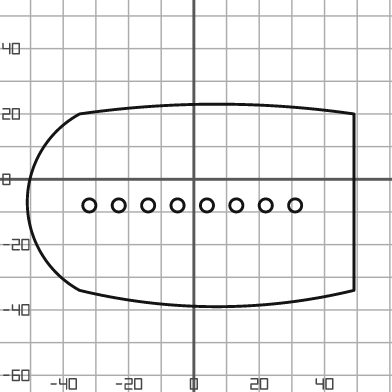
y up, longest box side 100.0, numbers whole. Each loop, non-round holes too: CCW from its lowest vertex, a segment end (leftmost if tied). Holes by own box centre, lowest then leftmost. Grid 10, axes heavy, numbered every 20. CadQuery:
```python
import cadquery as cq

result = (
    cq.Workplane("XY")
    .moveTo(-35.0, -34.0)
    .threePointArc((7.0, -39.0), (49.0, -34.0))
    .lineTo(49.0, 20.0)
    .threePointArc((7.0, 23.0), (-35.0, 20.0))
    .threePointArc((-51.0, -7.0), (-35.0, -34.0))
    .close()
    .moveTo(-32.0, -8.0)
    .circle(2.0)
    .moveTo(-23.0, -8.0)
    .circle(2.0)
    .moveTo(-14.0, -8.0)
    .circle(2.0)
    .moveTo(-5.0, -8.0)
    .circle(2.0)
    .moveTo(4.0, -8.0)
    .circle(2.0)
    .moveTo(13.0, -8.0)
    .circle(2.0)
    .moveTo(22.0, -8.0)
    .circle(2.0)
    .moveTo(31.0, -8.0)
    .circle(2.0)
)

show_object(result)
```